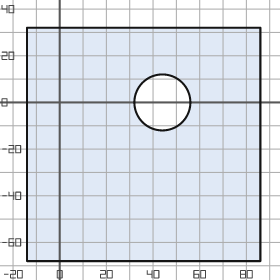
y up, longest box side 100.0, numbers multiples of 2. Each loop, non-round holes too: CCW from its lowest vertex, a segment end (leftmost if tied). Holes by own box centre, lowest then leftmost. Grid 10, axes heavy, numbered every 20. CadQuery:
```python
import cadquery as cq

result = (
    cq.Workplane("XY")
    .moveTo(-14.0, -68.0)
    .lineTo(86.0, -68.0)
    .lineTo(86.0, 32.0)
    .lineTo(-14.0, 32.0)
    .close()
    .moveTo(44.0, 0.0)
    .circle(12.0)
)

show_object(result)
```